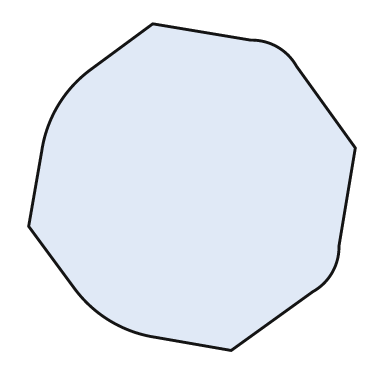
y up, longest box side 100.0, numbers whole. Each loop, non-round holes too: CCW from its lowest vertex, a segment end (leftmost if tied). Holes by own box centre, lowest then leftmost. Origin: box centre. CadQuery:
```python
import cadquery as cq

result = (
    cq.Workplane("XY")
    .moveTo(12.0, -50.0)
    .lineTo(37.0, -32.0)
    .threePointArc((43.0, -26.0), (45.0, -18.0))
    .lineTo(50.0, 12.0)
    .lineTo(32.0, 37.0)
    .threePointArc((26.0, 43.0), (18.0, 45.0))
    .lineTo(-12.0, 50.0)
    .lineTo(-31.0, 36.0)
    .threePointArc((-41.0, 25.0), (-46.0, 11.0))
    .lineTo(-50.0, -12.0)
    .lineTo(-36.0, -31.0)
    .threePointArc((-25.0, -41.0), (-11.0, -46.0))
    .close()
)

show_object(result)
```